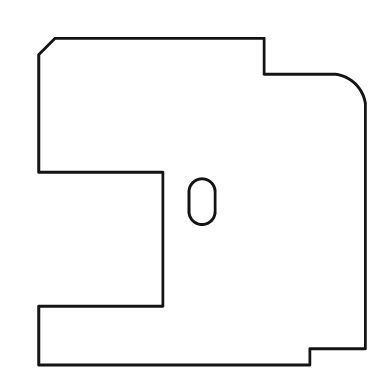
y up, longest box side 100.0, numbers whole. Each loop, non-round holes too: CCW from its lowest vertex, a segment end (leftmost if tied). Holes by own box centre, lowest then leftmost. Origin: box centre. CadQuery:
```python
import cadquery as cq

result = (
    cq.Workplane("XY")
    .moveTo(-50.0, -50.0)
    .lineTo(33.0, -50.0)
    .lineTo(33.0, -45.0)
    .lineTo(50.0, -45.0)
    .lineTo(50.0, 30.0)
    .threePointArc((47.0, 36.0), (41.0, 39.0))
    .lineTo(19.0, 39.0)
    .lineTo(19.0, 50.0)
    .lineTo(-45.0, 50.0)
    .lineTo(-50.0, 45.0)
    .lineTo(-50.0, 9.0)
    .lineTo(-12.0, 9.0)
    .lineTo(-12.0, -32.0)
    .lineTo(-50.0, -32.0)
    .close()
    .moveTo(-4.0, -3.0)
    .threePointArc((0.0, -7.0), (4.0, -3.0))
    .lineTo(4.0, 3.0)
    .threePointArc((0.0, 7.0), (-4.0, 3.0))
    .close()
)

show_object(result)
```